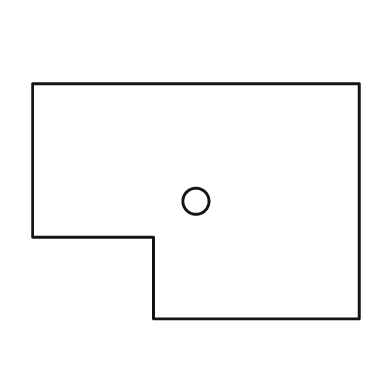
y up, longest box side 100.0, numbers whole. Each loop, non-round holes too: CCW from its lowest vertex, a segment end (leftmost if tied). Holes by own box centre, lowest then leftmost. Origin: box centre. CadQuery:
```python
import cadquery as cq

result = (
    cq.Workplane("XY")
    .moveTo(-13.0, -36.0)
    .lineTo(50.0, -36.0)
    .lineTo(50.0, 36.0)
    .lineTo(-50.0, 36.0)
    .lineTo(-50.0, -11.0)
    .lineTo(-13.0, -11.0)
    .close()
    .moveTo(0.0, 0.0)
    .circle(4.0)
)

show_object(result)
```